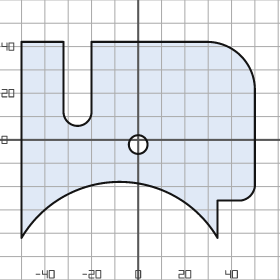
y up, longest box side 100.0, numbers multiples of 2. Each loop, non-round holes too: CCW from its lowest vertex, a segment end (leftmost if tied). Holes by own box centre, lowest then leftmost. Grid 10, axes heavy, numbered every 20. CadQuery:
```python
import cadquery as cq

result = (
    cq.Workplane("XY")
    .moveTo(-50.0, -42.0)
    .threePointArc((-8.0, -18.0), (34.0, -42.0))
    .lineTo(34.0, -26.0)
    .lineTo(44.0, -26.0)
    .threePointArc((48.0, -24.0), (50.0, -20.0))
    .lineTo(50.0, 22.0)
    .threePointArc((44.0, 36.0), (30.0, 42.0))
    .lineTo(-20.0, 42.0)
    .lineTo(-20.0, 12.0)
    .threePointArc((-26.0, 6.0), (-32.0, 12.0))
    .lineTo(-32.0, 42.0)
    .lineTo(-50.0, 42.0)
    .close()
    .moveTo(0.0, -2.0)
    .circle(4.0)
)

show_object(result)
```